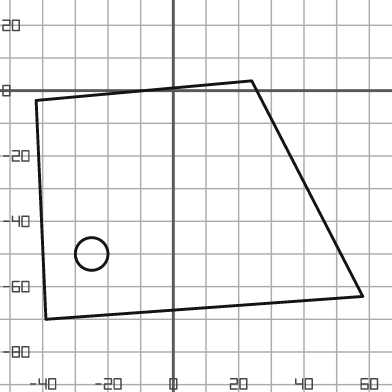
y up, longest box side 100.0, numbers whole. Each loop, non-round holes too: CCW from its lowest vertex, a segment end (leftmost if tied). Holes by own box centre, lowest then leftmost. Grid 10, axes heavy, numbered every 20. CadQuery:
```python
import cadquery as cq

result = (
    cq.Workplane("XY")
    .moveTo(-39.0, -70.0)
    .lineTo(58.0, -63.0)
    .lineTo(24.0, 3.0)
    .lineTo(-42.0, -3.0)
    .close()
    .moveTo(-25.0, -50.0)
    .circle(5.0)
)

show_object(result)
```